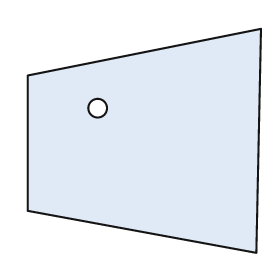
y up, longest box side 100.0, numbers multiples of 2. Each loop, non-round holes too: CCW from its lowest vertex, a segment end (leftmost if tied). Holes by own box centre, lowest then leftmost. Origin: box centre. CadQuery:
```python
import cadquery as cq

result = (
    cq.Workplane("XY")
    .moveTo(48.0, -48.0)
    .lineTo(50.0, 48.0)
    .lineTo(-50.0, 28.0)
    .lineTo(-50.0, -30.0)
    .close()
    .moveTo(-20.0, 14.0)
    .circle(4.0)
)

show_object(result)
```